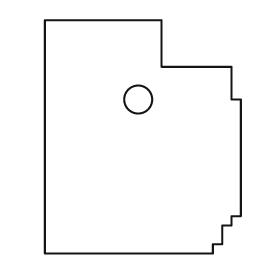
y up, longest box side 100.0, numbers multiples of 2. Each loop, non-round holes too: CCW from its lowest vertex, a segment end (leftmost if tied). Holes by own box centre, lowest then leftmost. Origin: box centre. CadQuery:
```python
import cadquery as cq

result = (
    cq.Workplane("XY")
    .moveTo(-42.0, -50.0)
    .lineTo(30.0, -50.0)
    .lineTo(30.0, -46.0)
    .lineTo(34.0, -46.0)
    .lineTo(34.0, -38.0)
    .lineTo(38.0, -38.0)
    .lineTo(38.0, -34.0)
    .lineTo(42.0, -34.0)
    .lineTo(42.0, 16.0)
    .lineTo(38.0, 16.0)
    .lineTo(38.0, 30.0)
    .lineTo(8.0, 30.0)
    .lineTo(8.0, 50.0)
    .lineTo(-42.0, 50.0)
    .close()
    .moveTo(-2.0, 16.0)
    .circle(6.0)
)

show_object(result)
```